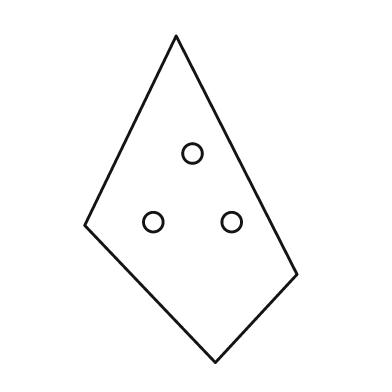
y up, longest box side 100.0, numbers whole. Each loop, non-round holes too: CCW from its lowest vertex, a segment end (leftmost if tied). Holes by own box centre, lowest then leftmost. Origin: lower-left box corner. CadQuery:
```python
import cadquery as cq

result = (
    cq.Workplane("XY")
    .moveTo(40.0, 0.0)
    .lineTo(65.0, 27.0)
    .lineTo(28.0, 100.0)
    .lineTo(0.0, 42.0)
    .close()
    .moveTo(21.0, 43.0)
    .circle(3.0)
    .moveTo(45.0, 43.0)
    .circle(3.0)
    .moveTo(33.0, 64.0)
    .circle(3.0)
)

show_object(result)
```